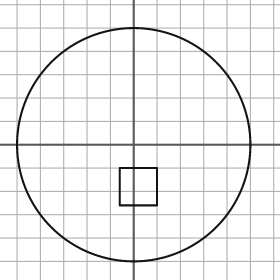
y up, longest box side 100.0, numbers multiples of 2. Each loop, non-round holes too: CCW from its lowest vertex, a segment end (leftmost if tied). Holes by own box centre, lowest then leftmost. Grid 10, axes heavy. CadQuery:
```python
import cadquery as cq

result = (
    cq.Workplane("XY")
    .moveTo(0.0, 0.0)
    .circle(50.0)
    .moveTo(-6.0, -26.0)
    .lineTo(10.0, -26.0)
    .lineTo(10.0, -10.0)
    .lineTo(-6.0, -10.0)
    .close()
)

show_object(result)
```